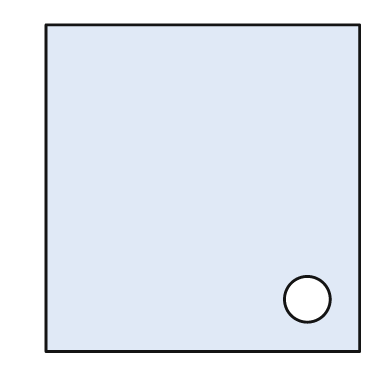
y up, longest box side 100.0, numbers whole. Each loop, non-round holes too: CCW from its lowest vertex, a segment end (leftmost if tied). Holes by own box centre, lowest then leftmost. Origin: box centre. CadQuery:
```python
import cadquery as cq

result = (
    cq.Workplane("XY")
    .moveTo(-48.0, -50.0)
    .lineTo(48.0, -50.0)
    .lineTo(48.0, 50.0)
    .lineTo(-48.0, 50.0)
    .close()
    .moveTo(32.0, -34.0)
    .circle(7.0)
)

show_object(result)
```